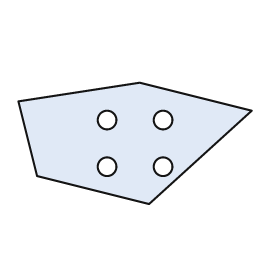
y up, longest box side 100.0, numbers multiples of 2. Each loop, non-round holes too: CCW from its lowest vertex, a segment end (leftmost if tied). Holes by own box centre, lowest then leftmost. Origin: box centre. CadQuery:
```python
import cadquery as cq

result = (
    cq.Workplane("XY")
    .moveTo(6.0, -26.0)
    .lineTo(50.0, 14.0)
    .lineTo(2.0, 26.0)
    .lineTo(-50.0, 18.0)
    .lineTo(-42.0, -14.0)
    .close()
    .moveTo(-12.0, -10.0)
    .circle(4.0)
    .moveTo(12.0, -10.0)
    .circle(4.0)
    .moveTo(-12.0, 10.0)
    .circle(4.0)
    .moveTo(12.0, 10.0)
    .circle(4.0)
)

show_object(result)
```